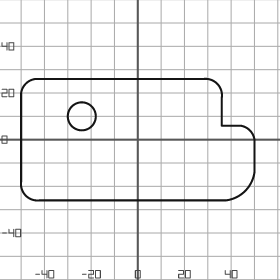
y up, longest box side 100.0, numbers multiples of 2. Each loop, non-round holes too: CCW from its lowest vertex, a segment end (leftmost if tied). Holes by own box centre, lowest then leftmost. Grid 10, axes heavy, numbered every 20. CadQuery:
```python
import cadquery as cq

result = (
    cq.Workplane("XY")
    .moveTo(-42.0, -26.0)
    .lineTo(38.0, -26.0)
    .threePointArc((46.0, -22.0), (50.0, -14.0))
    .lineTo(50.0, 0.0)
    .threePointArc((48.0, 4.0), (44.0, 6.0))
    .lineTo(36.0, 6.0)
    .lineTo(36.0, 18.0)
    .threePointArc((34.0, 24.0), (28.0, 26.0))
    .lineTo(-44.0, 26.0)
    .threePointArc((-48.0, 24.0), (-50.0, 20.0))
    .lineTo(-50.0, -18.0)
    .threePointArc((-48.0, -24.0), (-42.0, -26.0))
    .close()
    .moveTo(-24.0, 10.0)
    .circle(6.0)
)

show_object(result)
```